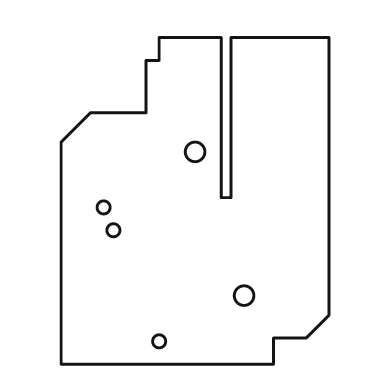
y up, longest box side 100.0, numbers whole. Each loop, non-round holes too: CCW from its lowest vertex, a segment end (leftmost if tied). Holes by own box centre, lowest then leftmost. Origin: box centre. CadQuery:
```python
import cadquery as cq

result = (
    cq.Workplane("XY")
    .moveTo(-41.0, -50.0)
    .lineTo(24.0, -50.0)
    .lineTo(24.0, -42.0)
    .lineTo(34.0, -42.0)
    .lineTo(41.0, -35.0)
    .lineTo(41.0, 50.0)
    .lineTo(11.0, 50.0)
    .lineTo(11.0, 1.0)
    .lineTo(8.0, 1.0)
    .lineTo(8.0, 50.0)
    .lineTo(-11.0, 50.0)
    .lineTo(-11.0, 43.0)
    .lineTo(-15.0, 43.0)
    .lineTo(-15.0, 27.0)
    .lineTo(-32.0, 27.0)
    .lineTo(-41.0, 18.0)
    .close()
    .moveTo(-11.0, -43.0)
    .circle(2.0)
    .moveTo(15.0, -29.0)
    .circle(3.0)
    .moveTo(-25.0, -9.0)
    .circle(2.0)
    .moveTo(-28.0, -2.0)
    .circle(2.0)
    .moveTo(0.0, 15.0)
    .circle(3.0)
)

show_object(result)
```